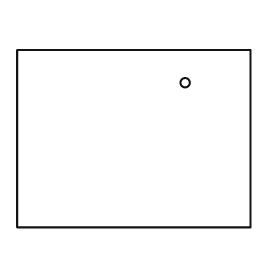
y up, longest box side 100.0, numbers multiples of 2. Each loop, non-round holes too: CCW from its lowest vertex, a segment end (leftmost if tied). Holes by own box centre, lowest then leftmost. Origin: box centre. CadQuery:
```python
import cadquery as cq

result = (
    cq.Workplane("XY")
    .moveTo(-50.0, -38.0)
    .lineTo(50.0, -38.0)
    .lineTo(50.0, 38.0)
    .lineTo(-50.0, 38.0)
    .close()
    .moveTo(22.0, 24.0)
    .circle(2.0)
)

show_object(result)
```